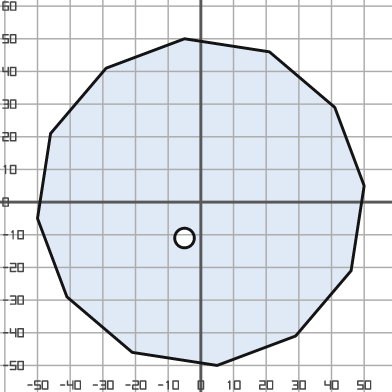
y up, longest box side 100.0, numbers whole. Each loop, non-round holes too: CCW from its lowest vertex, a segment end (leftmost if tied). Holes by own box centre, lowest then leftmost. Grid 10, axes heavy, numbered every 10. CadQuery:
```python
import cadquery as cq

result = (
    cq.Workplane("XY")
    .moveTo(5.0, -50.0)
    .lineTo(29.0, -41.0)
    .lineTo(46.0, -21.0)
    .lineTo(50.0, 5.0)
    .lineTo(41.0, 29.0)
    .lineTo(21.0, 46.0)
    .lineTo(-5.0, 50.0)
    .lineTo(-29.0, 41.0)
    .lineTo(-46.0, 21.0)
    .lineTo(-50.0, -5.0)
    .lineTo(-41.0, -29.0)
    .lineTo(-21.0, -46.0)
    .close()
    .moveTo(-5.0, -11.0)
    .circle(3.0)
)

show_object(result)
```